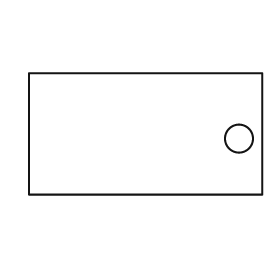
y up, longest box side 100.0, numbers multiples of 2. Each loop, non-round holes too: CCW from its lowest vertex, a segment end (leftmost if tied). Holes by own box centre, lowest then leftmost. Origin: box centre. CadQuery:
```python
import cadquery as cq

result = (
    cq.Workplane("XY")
    .moveTo(-50.0, -26.0)
    .lineTo(50.0, -26.0)
    .lineTo(50.0, 26.0)
    .lineTo(-50.0, 26.0)
    .close()
    .moveTo(40.0, -2.0)
    .circle(6.0)
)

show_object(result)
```